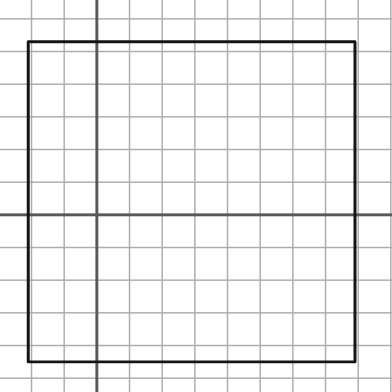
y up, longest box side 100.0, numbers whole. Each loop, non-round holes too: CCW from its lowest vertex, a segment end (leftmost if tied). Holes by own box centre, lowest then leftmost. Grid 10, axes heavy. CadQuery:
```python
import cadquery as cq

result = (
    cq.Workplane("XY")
    .moveTo(-21.0, -45.0)
    .lineTo(79.0, -45.0)
    .lineTo(79.0, 53.0)
    .lineTo(-21.0, 53.0)
    .close()
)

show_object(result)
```